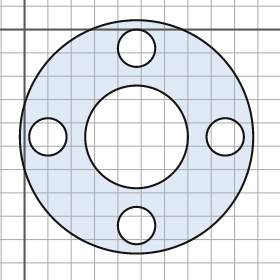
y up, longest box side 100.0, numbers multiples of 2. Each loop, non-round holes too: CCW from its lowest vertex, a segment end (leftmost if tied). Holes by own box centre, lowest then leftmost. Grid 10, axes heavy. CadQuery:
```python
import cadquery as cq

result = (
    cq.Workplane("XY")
    .moveTo(48.0, -46.0)
    .circle(50.0)
    .moveTo(48.0, -84.0)
    .circle(8.0)
    .moveTo(10.0, -46.0)
    .circle(8.0)
    .moveTo(48.0, -46.0)
    .circle(22.0)
    .moveTo(86.0, -46.0)
    .circle(8.0)
    .moveTo(48.0, -8.0)
    .circle(8.0)
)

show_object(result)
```